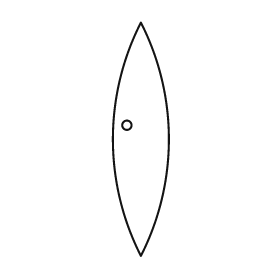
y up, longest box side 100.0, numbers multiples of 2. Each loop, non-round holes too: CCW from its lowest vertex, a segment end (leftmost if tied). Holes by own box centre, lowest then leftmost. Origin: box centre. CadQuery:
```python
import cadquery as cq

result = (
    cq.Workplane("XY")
    .moveTo(0.0, -50.0)
    .threePointArc((12.0, 0.0), (0.0, 50.0))
    .threePointArc((-12.0, 0.0), (0.0, -50.0))
    .close()
    .moveTo(-6.0, 6.0)
    .circle(2.0)
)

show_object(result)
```